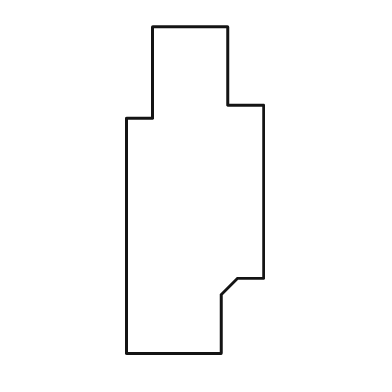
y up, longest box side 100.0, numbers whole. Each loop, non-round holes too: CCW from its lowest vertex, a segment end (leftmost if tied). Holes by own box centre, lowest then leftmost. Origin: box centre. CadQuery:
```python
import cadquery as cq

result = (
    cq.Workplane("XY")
    .moveTo(-21.0, -50.0)
    .lineTo(8.0, -50.0)
    .lineTo(8.0, -32.0)
    .lineTo(13.0, -27.0)
    .lineTo(21.0, -27.0)
    .lineTo(21.0, 26.0)
    .lineTo(10.0, 26.0)
    .lineTo(10.0, 50.0)
    .lineTo(-13.0, 50.0)
    .lineTo(-13.0, 22.0)
    .lineTo(-21.0, 22.0)
    .close()
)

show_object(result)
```